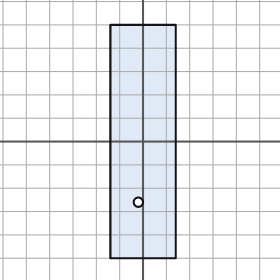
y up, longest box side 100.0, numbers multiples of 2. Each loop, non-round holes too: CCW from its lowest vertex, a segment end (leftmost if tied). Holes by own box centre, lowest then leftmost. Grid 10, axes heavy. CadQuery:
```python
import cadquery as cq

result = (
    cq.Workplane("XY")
    .moveTo(-14.0, -50.0)
    .lineTo(14.0, -50.0)
    .lineTo(14.0, 50.0)
    .lineTo(-14.0, 50.0)
    .close()
    .moveTo(-2.0, -26.0)
    .circle(2.0)
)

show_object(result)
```